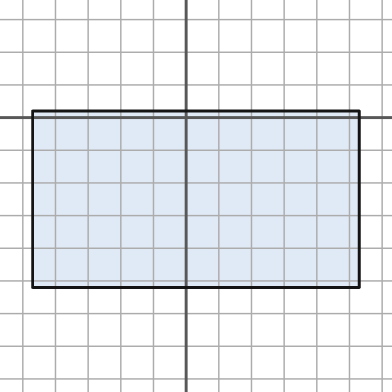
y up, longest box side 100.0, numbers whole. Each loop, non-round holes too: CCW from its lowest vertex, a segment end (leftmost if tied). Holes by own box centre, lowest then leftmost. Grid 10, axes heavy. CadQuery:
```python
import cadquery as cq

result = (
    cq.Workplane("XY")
    .moveTo(-47.0, -52.0)
    .lineTo(53.0, -52.0)
    .lineTo(53.0, 2.0)
    .lineTo(-47.0, 2.0)
    .close()
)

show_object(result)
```